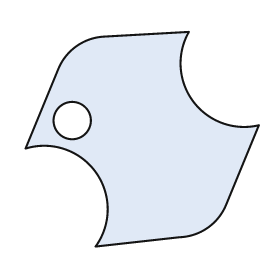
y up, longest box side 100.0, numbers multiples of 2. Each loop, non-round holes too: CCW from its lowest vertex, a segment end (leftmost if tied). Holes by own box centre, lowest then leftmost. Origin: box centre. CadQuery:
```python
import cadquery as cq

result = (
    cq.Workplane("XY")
    .moveTo(-20.0, -46.0)
    .lineTo(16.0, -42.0)
    .threePointArc((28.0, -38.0), (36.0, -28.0))
    .lineTo(50.0, 6.0)
    .threePointArc((22.0, 16.0), (20.0, 46.0))
    .lineTo(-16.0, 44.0)
    .threePointArc((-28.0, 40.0), (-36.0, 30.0))
    .lineTo(-50.0, -4.0)
    .threePointArc((-20.0, -14.0), (-20.0, -46.0))
    .close()
    .moveTo(-30.0, 8.0)
    .circle(8.0)
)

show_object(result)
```